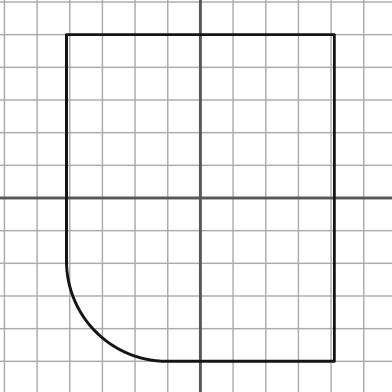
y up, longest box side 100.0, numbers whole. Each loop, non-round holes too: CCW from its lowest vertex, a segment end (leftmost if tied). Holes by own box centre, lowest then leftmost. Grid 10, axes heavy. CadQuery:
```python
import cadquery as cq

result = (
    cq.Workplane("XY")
    .moveTo(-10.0, -50.0)
    .lineTo(41.0, -50.0)
    .lineTo(41.0, 50.0)
    .lineTo(-41.0, 50.0)
    .lineTo(-41.0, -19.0)
    .threePointArc((-32.0, -41.0), (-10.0, -50.0))
    .close()
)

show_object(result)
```